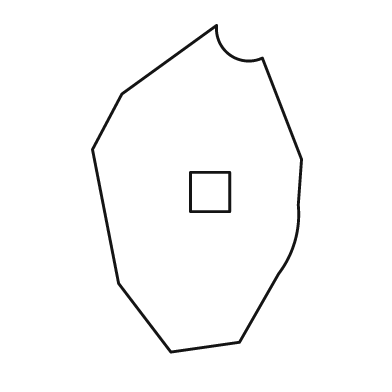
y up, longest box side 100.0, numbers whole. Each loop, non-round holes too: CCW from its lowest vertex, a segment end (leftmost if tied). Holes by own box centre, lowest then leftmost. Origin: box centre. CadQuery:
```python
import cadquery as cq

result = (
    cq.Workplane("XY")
    .moveTo(-8.0, -50.0)
    .lineTo(13.0, -47.0)
    .lineTo(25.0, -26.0)
    .threePointArc((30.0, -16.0), (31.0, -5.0))
    .lineTo(32.0, 9.0)
    .lineTo(20.0, 40.0)
    .threePointArc((10.0, 41.0), (6.0, 50.0))
    .lineTo(-23.0, 29.0)
    .lineTo(-32.0, 12.0)
    .lineTo(-24.0, -29.0)
    .close()
    .moveTo(-2.0, -7.0)
    .lineTo(10.0, -7.0)
    .lineTo(10.0, 5.0)
    .lineTo(-2.0, 5.0)
    .close()
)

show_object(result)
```